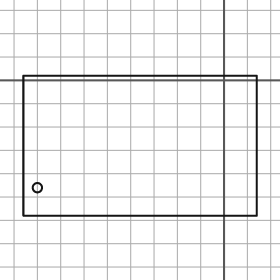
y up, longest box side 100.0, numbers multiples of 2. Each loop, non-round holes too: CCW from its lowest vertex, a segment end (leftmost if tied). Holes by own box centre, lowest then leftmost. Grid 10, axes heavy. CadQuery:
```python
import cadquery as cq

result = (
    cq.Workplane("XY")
    .moveTo(-86.0, -58.0)
    .lineTo(14.0, -58.0)
    .lineTo(14.0, 2.0)
    .lineTo(-86.0, 2.0)
    .close()
    .moveTo(-80.0, -46.0)
    .circle(2.0)
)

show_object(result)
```